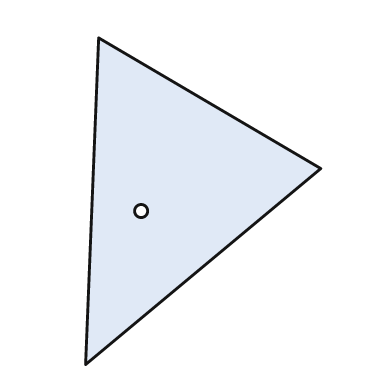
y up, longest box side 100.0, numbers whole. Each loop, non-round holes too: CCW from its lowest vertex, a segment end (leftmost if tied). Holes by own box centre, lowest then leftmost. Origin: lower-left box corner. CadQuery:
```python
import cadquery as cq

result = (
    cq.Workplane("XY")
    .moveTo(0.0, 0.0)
    .lineTo(72.0, 60.0)
    .lineTo(4.0, 100.0)
    .close()
    .moveTo(17.0, 47.0)
    .circle(2.0)
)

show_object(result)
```